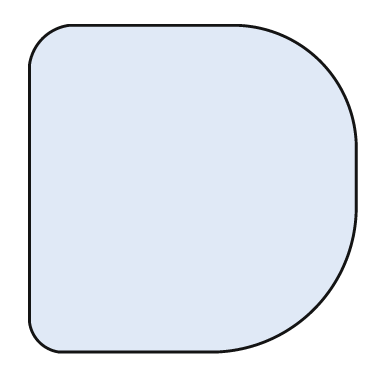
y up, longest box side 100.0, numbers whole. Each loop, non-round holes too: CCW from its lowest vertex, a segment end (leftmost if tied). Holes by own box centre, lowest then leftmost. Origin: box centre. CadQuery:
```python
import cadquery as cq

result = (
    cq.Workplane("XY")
    .moveTo(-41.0, -50.0)
    .lineTo(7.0, -50.0)
    .threePointArc((37.0, -37.0), (50.0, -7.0))
    .lineTo(50.0, 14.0)
    .threePointArc((39.0, 39.0), (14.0, 50.0))
    .lineTo(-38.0, 50.0)
    .threePointArc((-46.0, 46.0), (-50.0, 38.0))
    .lineTo(-50.0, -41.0)
    .threePointArc((-47.0, -47.0), (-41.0, -50.0))
    .close()
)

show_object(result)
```